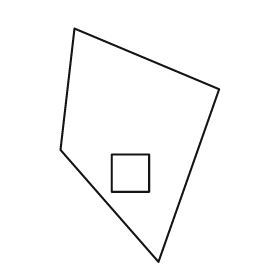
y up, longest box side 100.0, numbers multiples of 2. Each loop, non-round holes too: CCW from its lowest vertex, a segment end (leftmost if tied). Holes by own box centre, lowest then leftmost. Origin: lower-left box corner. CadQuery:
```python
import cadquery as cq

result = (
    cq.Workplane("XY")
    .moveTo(42.0, 0.0)
    .lineTo(68.0, 74.0)
    .lineTo(6.0, 100.0)
    .lineTo(0.0, 48.0)
    .close()
    .moveTo(22.0, 30.0)
    .lineTo(38.0, 30.0)
    .lineTo(38.0, 46.0)
    .lineTo(22.0, 46.0)
    .close()
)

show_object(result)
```